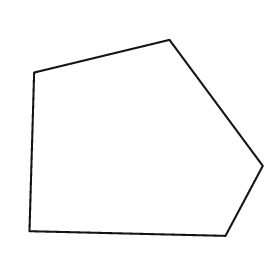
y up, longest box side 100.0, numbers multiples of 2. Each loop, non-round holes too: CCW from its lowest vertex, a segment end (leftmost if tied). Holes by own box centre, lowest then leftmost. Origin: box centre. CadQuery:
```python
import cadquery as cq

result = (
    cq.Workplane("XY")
    .moveTo(34.0, -42.0)
    .lineTo(50.0, -12.0)
    .lineTo(10.0, 42.0)
    .lineTo(-48.0, 28.0)
    .lineTo(-50.0, -40.0)
    .close()
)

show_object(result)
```